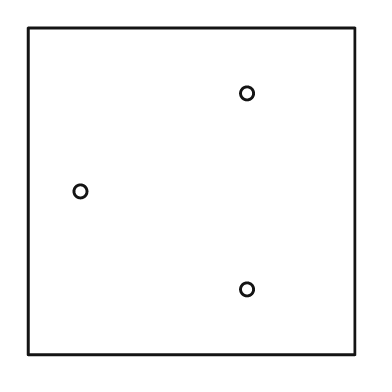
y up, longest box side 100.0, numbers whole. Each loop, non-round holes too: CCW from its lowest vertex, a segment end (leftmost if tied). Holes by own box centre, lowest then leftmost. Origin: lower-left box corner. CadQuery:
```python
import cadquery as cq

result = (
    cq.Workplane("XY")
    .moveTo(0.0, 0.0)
    .lineTo(100.0, 0.0)
    .lineTo(100.0, 100.0)
    .lineTo(0.0, 100.0)
    .close()
    .moveTo(67.0, 20.0)
    .circle(2.0)
    .moveTo(16.0, 50.0)
    .circle(2.0)
    .moveTo(67.0, 80.0)
    .circle(2.0)
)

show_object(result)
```